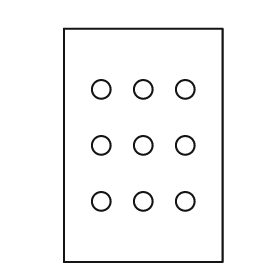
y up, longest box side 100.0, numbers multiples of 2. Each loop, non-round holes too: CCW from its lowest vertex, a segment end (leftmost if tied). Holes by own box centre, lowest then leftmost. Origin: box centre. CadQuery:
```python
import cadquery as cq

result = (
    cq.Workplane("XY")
    .moveTo(-34.0, -50.0)
    .lineTo(34.0, -50.0)
    .lineTo(34.0, 50.0)
    .lineTo(-34.0, 50.0)
    .close()
    .moveTo(-18.0, -24.0)
    .circle(4.0)
    .moveTo(0.0, -24.0)
    .circle(4.0)
    .moveTo(18.0, -24.0)
    .circle(4.0)
    .moveTo(-18.0, 0.0)
    .circle(4.0)
    .moveTo(0.0, 0.0)
    .circle(4.0)
    .moveTo(18.0, 0.0)
    .circle(4.0)
    .moveTo(-18.0, 24.0)
    .circle(4.0)
    .moveTo(0.0, 24.0)
    .circle(4.0)
    .moveTo(18.0, 24.0)
    .circle(4.0)
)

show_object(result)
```